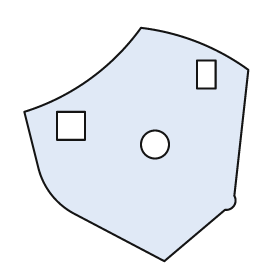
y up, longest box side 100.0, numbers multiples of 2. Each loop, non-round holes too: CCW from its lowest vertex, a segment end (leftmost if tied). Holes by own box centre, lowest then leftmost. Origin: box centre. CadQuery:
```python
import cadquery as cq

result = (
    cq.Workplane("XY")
    .moveTo(12.0, -50.0)
    .lineTo(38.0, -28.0)
    .threePointArc((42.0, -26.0), (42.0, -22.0))
    .lineTo(48.0, 32.0)
    .threePointArc((26.0, 44.0), (2.0, 50.0))
    .threePointArc((-20.0, 28.0), (-48.0, 14.0))
    .lineTo(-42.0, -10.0)
    .threePointArc((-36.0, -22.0), (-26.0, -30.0))
    .close()
    .moveTo(8.0, 0.0)
    .circle(6.0)
    .moveTo(-34.0, 2.0)
    .lineTo(-22.0, 2.0)
    .lineTo(-22.0, 14.0)
    .lineTo(-34.0, 14.0)
    .close()
    .moveTo(26.0, 24.0)
    .lineTo(34.0, 24.0)
    .lineTo(34.0, 36.0)
    .lineTo(26.0, 36.0)
    .close()
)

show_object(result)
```